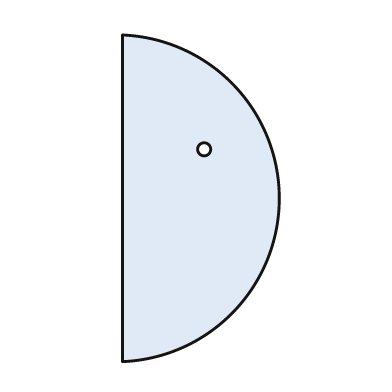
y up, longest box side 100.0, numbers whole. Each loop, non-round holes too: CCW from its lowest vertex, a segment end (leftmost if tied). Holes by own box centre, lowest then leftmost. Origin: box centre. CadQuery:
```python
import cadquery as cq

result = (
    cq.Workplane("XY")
    .moveTo(-24.0, -50.0)
    .threePointArc((24.0, 0.0), (-24.0, 50.0))
    .close()
    .moveTo(1.0, 15.0)
    .circle(2.0)
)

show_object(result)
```